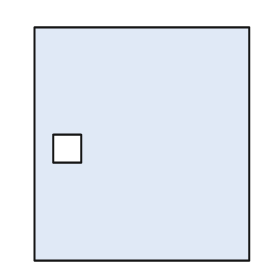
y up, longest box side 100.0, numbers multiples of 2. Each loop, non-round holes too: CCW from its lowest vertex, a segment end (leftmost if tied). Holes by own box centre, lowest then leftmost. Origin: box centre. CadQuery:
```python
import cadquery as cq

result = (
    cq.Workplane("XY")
    .moveTo(-46.0, -50.0)
    .lineTo(46.0, -50.0)
    .lineTo(46.0, 50.0)
    .lineTo(-46.0, 50.0)
    .close()
    .moveTo(-38.0, -8.0)
    .lineTo(-26.0, -8.0)
    .lineTo(-26.0, 4.0)
    .lineTo(-38.0, 4.0)
    .close()
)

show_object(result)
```